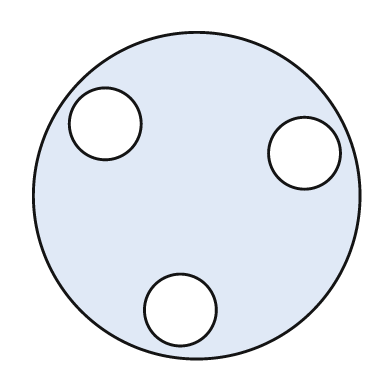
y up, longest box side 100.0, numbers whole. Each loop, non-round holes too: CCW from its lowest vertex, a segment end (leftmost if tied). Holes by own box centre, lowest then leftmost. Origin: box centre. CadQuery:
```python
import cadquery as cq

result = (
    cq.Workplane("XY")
    .moveTo(0.0, 0.0)
    .circle(50.0)
    .moveTo(-5.0, -35.0)
    .circle(11.0)
    .moveTo(33.0, 13.0)
    .circle(11.0)
    .moveTo(-28.0, 22.0)
    .circle(11.0)
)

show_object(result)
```